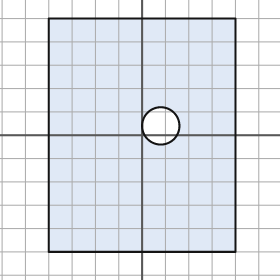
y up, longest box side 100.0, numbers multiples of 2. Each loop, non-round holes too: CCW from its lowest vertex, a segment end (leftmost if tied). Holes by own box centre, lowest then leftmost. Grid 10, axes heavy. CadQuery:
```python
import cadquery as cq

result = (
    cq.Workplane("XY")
    .moveTo(-40.0, -50.0)
    .lineTo(40.0, -50.0)
    .lineTo(40.0, 50.0)
    .lineTo(-40.0, 50.0)
    .close()
    .moveTo(8.0, 4.0)
    .circle(8.0)
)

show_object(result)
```